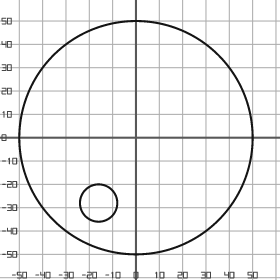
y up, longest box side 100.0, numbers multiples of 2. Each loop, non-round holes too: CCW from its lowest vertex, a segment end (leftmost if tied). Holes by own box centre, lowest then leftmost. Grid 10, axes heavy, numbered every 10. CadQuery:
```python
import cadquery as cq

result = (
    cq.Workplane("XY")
    .moveTo(0.0, 0.0)
    .circle(50.0)
    .moveTo(-16.0, -28.0)
    .circle(8.0)
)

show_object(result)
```